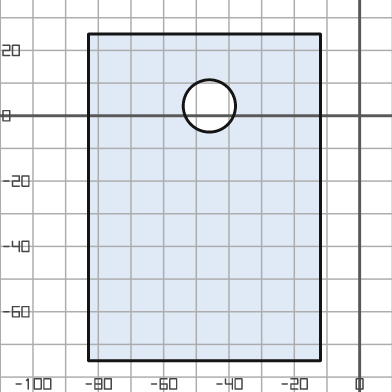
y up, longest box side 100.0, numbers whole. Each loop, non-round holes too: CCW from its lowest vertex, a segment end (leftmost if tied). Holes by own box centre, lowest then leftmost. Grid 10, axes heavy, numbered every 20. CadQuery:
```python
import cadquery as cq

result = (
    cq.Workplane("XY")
    .moveTo(-83.0, -75.0)
    .lineTo(-12.0, -75.0)
    .lineTo(-12.0, 25.0)
    .lineTo(-83.0, 25.0)
    .close()
    .moveTo(-46.0, 3.0)
    .circle(8.0)
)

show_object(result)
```